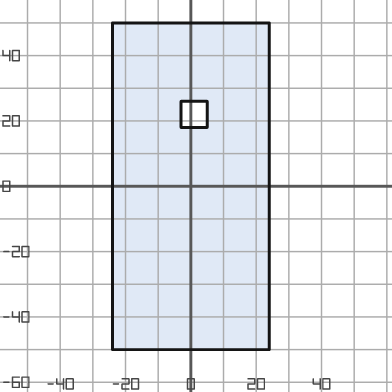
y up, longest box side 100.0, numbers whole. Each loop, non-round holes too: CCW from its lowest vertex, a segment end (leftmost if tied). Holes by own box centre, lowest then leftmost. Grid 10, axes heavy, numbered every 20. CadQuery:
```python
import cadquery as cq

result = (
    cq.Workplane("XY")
    .moveTo(-24.0, -50.0)
    .lineTo(24.0, -50.0)
    .lineTo(24.0, 50.0)
    .lineTo(-24.0, 50.0)
    .close()
    .moveTo(-3.0, 18.0)
    .lineTo(5.0, 18.0)
    .lineTo(5.0, 26.0)
    .lineTo(-3.0, 26.0)
    .close()
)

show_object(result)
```